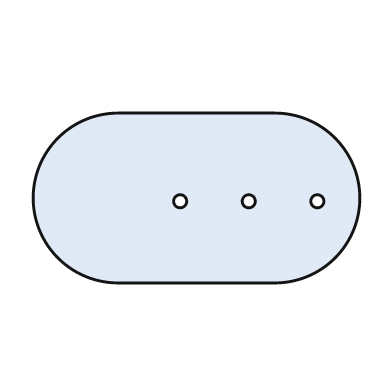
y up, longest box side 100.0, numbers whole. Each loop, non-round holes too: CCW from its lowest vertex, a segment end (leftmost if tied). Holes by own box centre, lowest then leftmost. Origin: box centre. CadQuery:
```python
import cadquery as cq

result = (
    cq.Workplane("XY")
    .moveTo(-24.0, -26.0)
    .lineTo(24.0, -26.0)
    .threePointArc((50.0, 0.0), (24.0, 26.0))
    .lineTo(-24.0, 26.0)
    .threePointArc((-50.0, 0.0), (-24.0, -26.0))
    .close()
    .moveTo(-5.0, -1.0)
    .circle(2.0)
    .moveTo(16.0, -1.0)
    .circle(2.0)
    .moveTo(37.0, -1.0)
    .circle(2.0)
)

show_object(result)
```